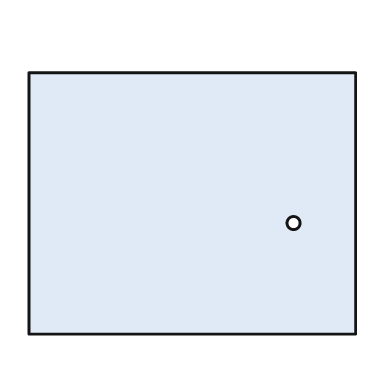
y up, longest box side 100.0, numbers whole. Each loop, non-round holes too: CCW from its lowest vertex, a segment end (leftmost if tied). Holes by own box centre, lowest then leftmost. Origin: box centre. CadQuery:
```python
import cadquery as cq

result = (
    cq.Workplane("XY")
    .moveTo(-50.0, -40.0)
    .lineTo(50.0, -40.0)
    .lineTo(50.0, 40.0)
    .lineTo(-50.0, 40.0)
    .close()
    .moveTo(31.0, -6.0)
    .circle(2.0)
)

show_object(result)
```